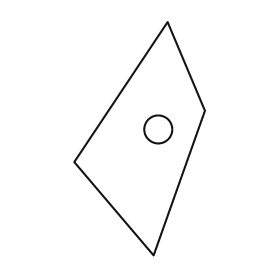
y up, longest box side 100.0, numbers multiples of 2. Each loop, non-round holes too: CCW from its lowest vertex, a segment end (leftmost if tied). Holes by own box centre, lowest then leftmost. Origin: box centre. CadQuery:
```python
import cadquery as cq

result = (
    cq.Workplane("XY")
    .moveTo(6.0, -50.0)
    .lineTo(28.0, 12.0)
    .lineTo(12.0, 50.0)
    .lineTo(-28.0, -10.0)
    .close()
    .moveTo(8.0, 4.0)
    .circle(6.0)
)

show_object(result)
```